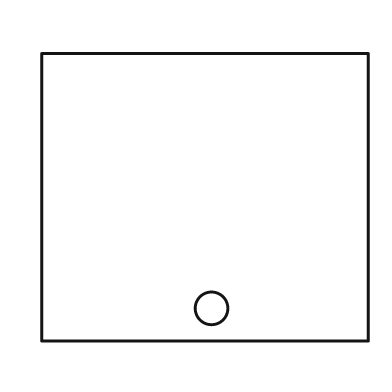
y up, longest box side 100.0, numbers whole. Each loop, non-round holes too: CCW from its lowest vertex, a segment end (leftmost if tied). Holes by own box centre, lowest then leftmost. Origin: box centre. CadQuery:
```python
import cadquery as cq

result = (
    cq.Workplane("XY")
    .moveTo(-50.0, -44.0)
    .lineTo(50.0, -44.0)
    .lineTo(50.0, 44.0)
    .lineTo(-50.0, 44.0)
    .close()
    .moveTo(2.0, -34.0)
    .circle(5.0)
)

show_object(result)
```